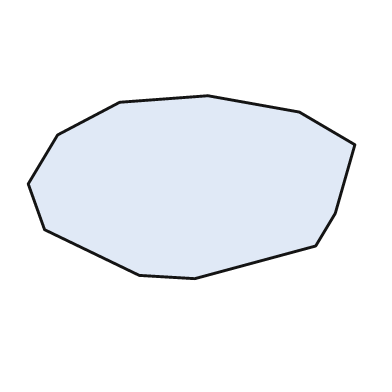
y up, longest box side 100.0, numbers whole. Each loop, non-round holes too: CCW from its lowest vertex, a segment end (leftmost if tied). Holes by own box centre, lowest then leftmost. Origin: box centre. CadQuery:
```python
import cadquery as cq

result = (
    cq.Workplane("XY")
    .moveTo(1.0, -28.0)
    .lineTo(38.0, -18.0)
    .lineTo(44.0, -8.0)
    .lineTo(50.0, 13.0)
    .lineTo(33.0, 23.0)
    .lineTo(5.0, 28.0)
    .lineTo(-22.0, 26.0)
    .lineTo(-41.0, 16.0)
    .lineTo(-50.0, 1.0)
    .lineTo(-45.0, -13.0)
    .lineTo(-16.0, -27.0)
    .close()
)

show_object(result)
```